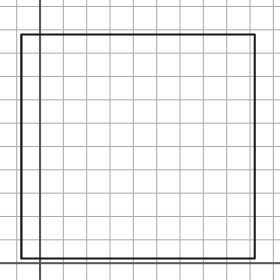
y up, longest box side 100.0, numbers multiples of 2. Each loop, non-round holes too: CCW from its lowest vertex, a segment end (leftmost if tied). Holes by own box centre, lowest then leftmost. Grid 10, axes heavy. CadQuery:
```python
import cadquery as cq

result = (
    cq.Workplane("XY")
    .moveTo(-8.0, 2.0)
    .lineTo(92.0, 2.0)
    .lineTo(92.0, 98.0)
    .lineTo(-8.0, 98.0)
    .close()
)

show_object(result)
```